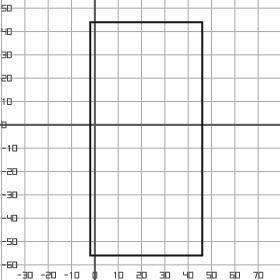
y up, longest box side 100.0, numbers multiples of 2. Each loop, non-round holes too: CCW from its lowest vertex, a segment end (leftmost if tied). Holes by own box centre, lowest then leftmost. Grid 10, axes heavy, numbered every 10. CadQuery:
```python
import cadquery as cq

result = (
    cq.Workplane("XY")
    .moveTo(-2.0, -56.0)
    .lineTo(46.0, -56.0)
    .lineTo(46.0, 44.0)
    .lineTo(-2.0, 44.0)
    .close()
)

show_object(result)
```